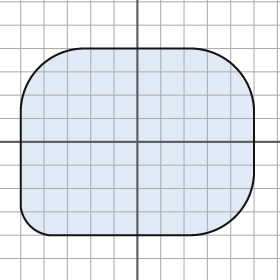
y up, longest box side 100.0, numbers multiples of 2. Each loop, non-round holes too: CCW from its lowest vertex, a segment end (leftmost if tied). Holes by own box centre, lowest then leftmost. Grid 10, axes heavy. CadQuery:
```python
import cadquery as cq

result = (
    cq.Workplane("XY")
    .moveTo(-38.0, -40.0)
    .lineTo(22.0, -40.0)
    .threePointArc((42.0, -32.0), (50.0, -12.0))
    .lineTo(50.0, 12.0)
    .threePointArc((42.0, 32.0), (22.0, 40.0))
    .lineTo(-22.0, 40.0)
    .threePointArc((-42.0, 32.0), (-50.0, 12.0))
    .lineTo(-50.0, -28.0)
    .threePointArc((-46.0, -36.0), (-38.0, -40.0))
    .close()
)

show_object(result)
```